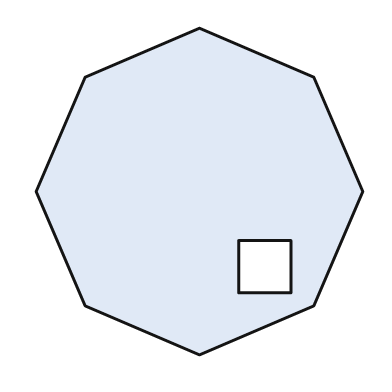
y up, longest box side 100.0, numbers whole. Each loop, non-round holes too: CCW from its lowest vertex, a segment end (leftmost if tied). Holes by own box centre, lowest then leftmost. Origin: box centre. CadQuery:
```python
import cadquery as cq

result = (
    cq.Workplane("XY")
    .moveTo(0.0, -50.0)
    .lineTo(35.0, -35.0)
    .lineTo(50.0, 0.0)
    .lineTo(35.0, 35.0)
    .lineTo(0.0, 50.0)
    .lineTo(-35.0, 35.0)
    .lineTo(-50.0, 0.0)
    .lineTo(-35.0, -35.0)
    .close()
    .moveTo(12.0, -31.0)
    .lineTo(28.0, -31.0)
    .lineTo(28.0, -15.0)
    .lineTo(12.0, -15.0)
    .close()
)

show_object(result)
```